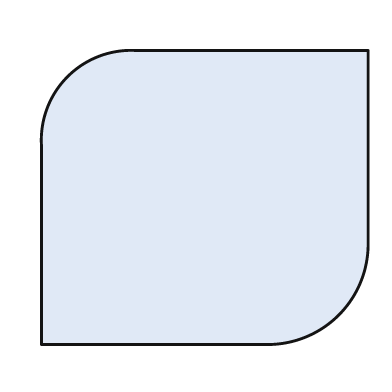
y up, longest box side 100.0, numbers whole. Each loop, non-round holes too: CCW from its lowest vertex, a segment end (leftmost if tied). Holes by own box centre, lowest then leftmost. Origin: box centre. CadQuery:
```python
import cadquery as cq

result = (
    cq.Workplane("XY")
    .moveTo(-50.0, -45.0)
    .lineTo(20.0, -45.0)
    .threePointArc((41.0, -36.0), (50.0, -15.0))
    .lineTo(50.0, 45.0)
    .lineTo(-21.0, 45.0)
    .threePointArc((-42.0, 37.0), (-50.0, 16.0))
    .close()
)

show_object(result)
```